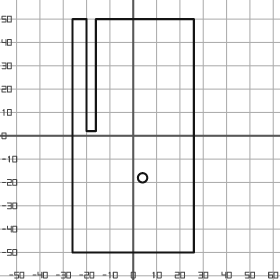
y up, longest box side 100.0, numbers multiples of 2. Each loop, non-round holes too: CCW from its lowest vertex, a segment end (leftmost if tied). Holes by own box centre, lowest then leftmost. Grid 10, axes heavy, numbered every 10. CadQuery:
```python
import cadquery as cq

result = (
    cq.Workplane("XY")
    .moveTo(-26.0, -50.0)
    .lineTo(26.0, -50.0)
    .lineTo(26.0, 50.0)
    .lineTo(-16.0, 50.0)
    .lineTo(-16.0, 2.0)
    .lineTo(-20.0, 2.0)
    .lineTo(-20.0, 50.0)
    .lineTo(-26.0, 50.0)
    .close()
    .moveTo(4.0, -18.0)
    .circle(2.0)
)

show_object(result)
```